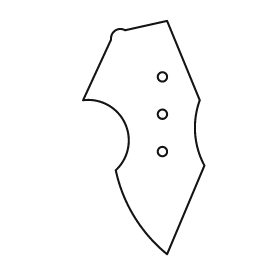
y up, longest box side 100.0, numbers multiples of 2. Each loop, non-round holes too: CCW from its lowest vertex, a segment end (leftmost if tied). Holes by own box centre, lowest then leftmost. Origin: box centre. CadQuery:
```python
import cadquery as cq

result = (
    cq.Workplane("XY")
    .moveTo(10.0, -50.0)
    .lineTo(26.0, -12.0)
    .threePointArc((22.0, 2.0), (24.0, 16.0))
    .lineTo(10.0, 50.0)
    .lineTo(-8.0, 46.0)
    .threePointArc((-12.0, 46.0), (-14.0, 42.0))
    .lineTo(-26.0, 16.0)
    .threePointArc((-8.0, 6.0), (-12.0, -14.0))
    .threePointArc((-4.0, -34.0), (10.0, -50.0))
    .close()
    .moveTo(8.0, -6.0)
    .circle(2.0)
    .moveTo(8.0, 10.0)
    .circle(2.0)
    .moveTo(8.0, 26.0)
    .circle(2.0)
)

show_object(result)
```